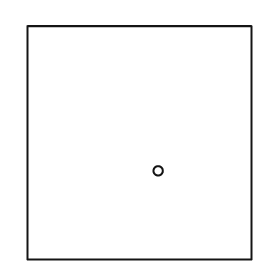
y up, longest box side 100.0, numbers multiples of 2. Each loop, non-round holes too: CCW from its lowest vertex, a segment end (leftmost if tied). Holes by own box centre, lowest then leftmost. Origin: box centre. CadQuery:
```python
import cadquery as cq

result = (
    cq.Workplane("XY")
    .moveTo(-48.0, -50.0)
    .lineTo(48.0, -50.0)
    .lineTo(48.0, 50.0)
    .lineTo(-48.0, 50.0)
    .close()
    .moveTo(8.0, -12.0)
    .circle(2.0)
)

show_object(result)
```